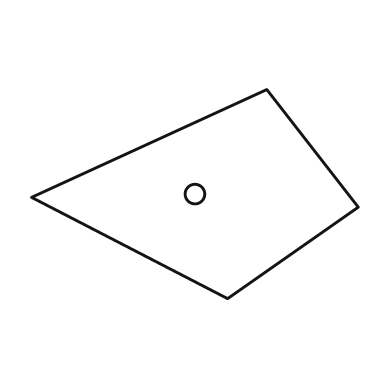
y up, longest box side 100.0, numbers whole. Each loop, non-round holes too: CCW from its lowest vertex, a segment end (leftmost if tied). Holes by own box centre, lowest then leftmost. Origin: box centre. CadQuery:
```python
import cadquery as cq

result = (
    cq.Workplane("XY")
    .moveTo(10.0, -32.0)
    .lineTo(50.0, -4.0)
    .lineTo(22.0, 32.0)
    .lineTo(-50.0, -1.0)
    .close()
    .moveTo(0.0, 0.0)
    .circle(3.0)
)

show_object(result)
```